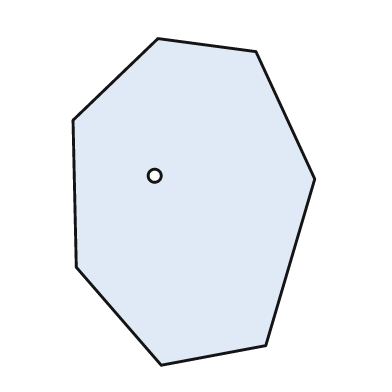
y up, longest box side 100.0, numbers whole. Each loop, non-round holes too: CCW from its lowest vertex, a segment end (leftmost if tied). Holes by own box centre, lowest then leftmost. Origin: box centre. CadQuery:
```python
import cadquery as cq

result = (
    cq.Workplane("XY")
    .moveTo(-10.0, -50.0)
    .lineTo(22.0, -44.0)
    .lineTo(37.0, 7.0)
    .lineTo(19.0, 46.0)
    .lineTo(-11.0, 50.0)
    .lineTo(-37.0, 25.0)
    .lineTo(-36.0, -20.0)
    .close()
    .moveTo(-12.0, 8.0)
    .circle(2.0)
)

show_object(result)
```